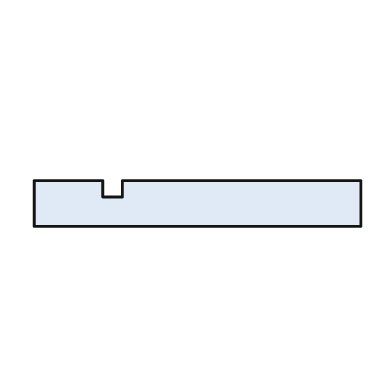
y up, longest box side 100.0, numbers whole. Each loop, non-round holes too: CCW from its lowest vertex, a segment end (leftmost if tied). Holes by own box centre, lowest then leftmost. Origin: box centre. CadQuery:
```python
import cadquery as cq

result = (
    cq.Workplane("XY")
    .moveTo(-50.0, -7.0)
    .lineTo(50.0, -7.0)
    .lineTo(50.0, 7.0)
    .lineTo(-23.0, 7.0)
    .lineTo(-23.0, 2.0)
    .lineTo(-29.0, 2.0)
    .lineTo(-29.0, 7.0)
    .lineTo(-50.0, 7.0)
    .close()
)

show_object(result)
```